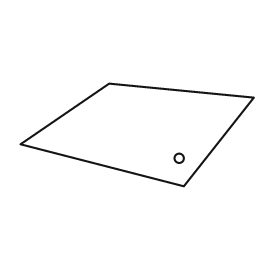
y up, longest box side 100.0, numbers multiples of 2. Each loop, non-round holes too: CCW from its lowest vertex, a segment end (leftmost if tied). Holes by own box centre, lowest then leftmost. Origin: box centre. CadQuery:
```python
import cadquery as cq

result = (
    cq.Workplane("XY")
    .moveTo(20.0, -22.0)
    .lineTo(50.0, 16.0)
    .lineTo(-12.0, 22.0)
    .lineTo(-50.0, -4.0)
    .close()
    .moveTo(18.0, -10.0)
    .circle(2.0)
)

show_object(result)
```